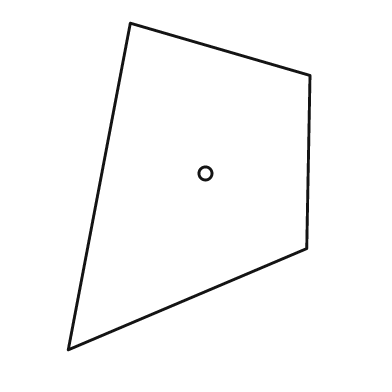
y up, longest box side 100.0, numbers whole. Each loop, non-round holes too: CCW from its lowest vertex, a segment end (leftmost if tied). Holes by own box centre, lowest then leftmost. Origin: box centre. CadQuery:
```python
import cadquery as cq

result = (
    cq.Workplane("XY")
    .moveTo(-37.0, -50.0)
    .lineTo(36.0, -19.0)
    .lineTo(37.0, 34.0)
    .lineTo(-18.0, 50.0)
    .close()
    .moveTo(5.0, 4.0)
    .circle(2.0)
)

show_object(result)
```